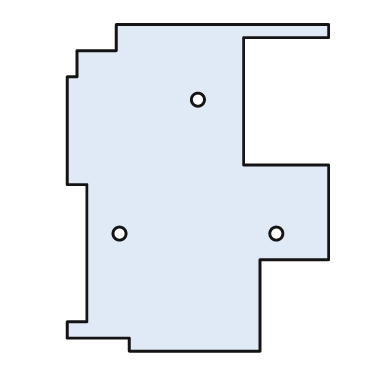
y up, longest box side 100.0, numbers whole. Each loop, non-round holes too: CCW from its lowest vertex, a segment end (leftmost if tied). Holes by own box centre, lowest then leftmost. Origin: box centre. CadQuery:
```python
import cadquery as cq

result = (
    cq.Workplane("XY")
    .moveTo(-21.0, -50.0)
    .lineTo(19.0, -50.0)
    .lineTo(19.0, -22.0)
    .lineTo(40.0, -22.0)
    .lineTo(40.0, 7.0)
    .lineTo(14.0, 7.0)
    .lineTo(14.0, 46.0)
    .lineTo(40.0, 46.0)
    .lineTo(40.0, 50.0)
    .lineTo(-25.0, 50.0)
    .lineTo(-25.0, 42.0)
    .lineTo(-37.0, 42.0)
    .lineTo(-37.0, 34.0)
    .lineTo(-40.0, 34.0)
    .lineTo(-40.0, 1.0)
    .lineTo(-34.0, 1.0)
    .lineTo(-34.0, -41.0)
    .lineTo(-40.0, -41.0)
    .lineTo(-40.0, -46.0)
    .lineTo(-21.0, -46.0)
    .close()
    .moveTo(-24.0, -14.0)
    .circle(2.0)
    .moveTo(24.0, -14.0)
    .circle(2.0)
    .moveTo(0.0, 27.0)
    .circle(2.0)
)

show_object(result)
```